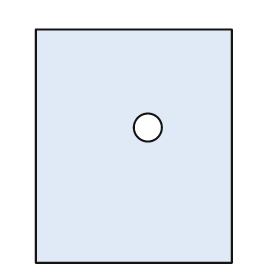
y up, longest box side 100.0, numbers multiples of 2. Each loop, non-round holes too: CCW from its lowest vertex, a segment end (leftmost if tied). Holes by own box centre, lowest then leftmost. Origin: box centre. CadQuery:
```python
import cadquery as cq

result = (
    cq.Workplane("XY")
    .moveTo(-42.0, -50.0)
    .lineTo(42.0, -50.0)
    .lineTo(42.0, 50.0)
    .lineTo(-42.0, 50.0)
    .close()
    .moveTo(6.0, 8.0)
    .circle(6.0)
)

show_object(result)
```